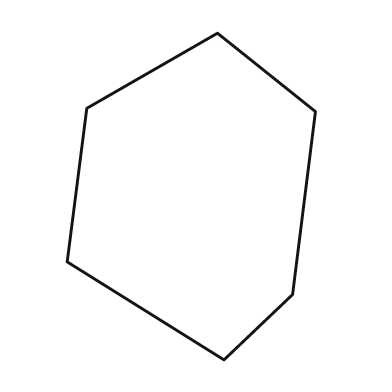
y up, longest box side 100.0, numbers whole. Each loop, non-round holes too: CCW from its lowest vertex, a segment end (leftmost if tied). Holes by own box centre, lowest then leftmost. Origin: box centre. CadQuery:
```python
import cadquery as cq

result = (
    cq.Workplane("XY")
    .moveTo(10.0, -50.0)
    .lineTo(31.0, -30.0)
    .lineTo(38.0, 26.0)
    .lineTo(8.0, 50.0)
    .lineTo(-32.0, 27.0)
    .lineTo(-38.0, -20.0)
    .close()
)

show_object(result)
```